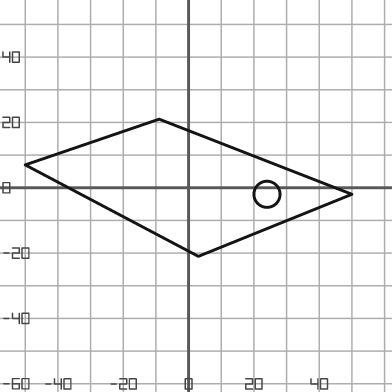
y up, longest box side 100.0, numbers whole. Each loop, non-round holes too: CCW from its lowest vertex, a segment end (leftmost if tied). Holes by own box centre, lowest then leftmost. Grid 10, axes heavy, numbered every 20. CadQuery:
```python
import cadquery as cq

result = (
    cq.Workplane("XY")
    .moveTo(3.0, -21.0)
    .lineTo(50.0, -2.0)
    .lineTo(-9.0, 21.0)
    .lineTo(-50.0, 7.0)
    .close()
    .moveTo(24.0, -2.0)
    .circle(4.0)
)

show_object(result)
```